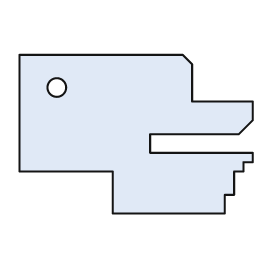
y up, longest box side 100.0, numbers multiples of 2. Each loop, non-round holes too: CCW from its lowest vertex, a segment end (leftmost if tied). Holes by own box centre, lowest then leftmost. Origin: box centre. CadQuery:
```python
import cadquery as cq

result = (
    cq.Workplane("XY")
    .moveTo(-10.0, -34.0)
    .lineTo(38.0, -34.0)
    .lineTo(38.0, -26.0)
    .lineTo(42.0, -26.0)
    .lineTo(42.0, -16.0)
    .lineTo(46.0, -16.0)
    .lineTo(46.0, -12.0)
    .lineTo(50.0, -12.0)
    .lineTo(50.0, -8.0)
    .lineTo(6.0, -8.0)
    .lineTo(6.0, 0.0)
    .lineTo(44.0, 0.0)
    .lineTo(50.0, 6.0)
    .lineTo(50.0, 14.0)
    .lineTo(24.0, 14.0)
    .lineTo(24.0, 30.0)
    .lineTo(20.0, 34.0)
    .lineTo(-50.0, 34.0)
    .lineTo(-50.0, -16.0)
    .lineTo(-10.0, -16.0)
    .close()
    .moveTo(-34.0, 20.0)
    .circle(4.0)
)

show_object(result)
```